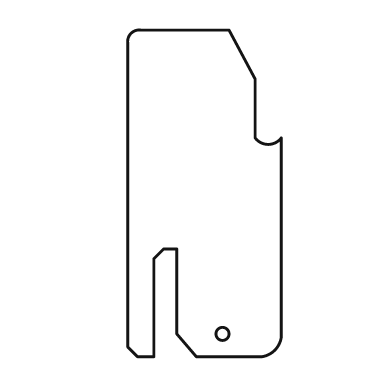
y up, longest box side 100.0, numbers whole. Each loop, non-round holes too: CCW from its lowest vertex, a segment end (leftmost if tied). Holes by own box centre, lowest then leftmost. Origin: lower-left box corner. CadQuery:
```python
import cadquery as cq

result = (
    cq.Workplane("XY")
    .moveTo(3.0, 0.0)
    .lineTo(8.0, 0.0)
    .lineTo(8.0, 30.0)
    .lineTo(11.0, 33.0)
    .lineTo(15.0, 33.0)
    .lineTo(15.0, 7.0)
    .lineTo(21.0, 0.0)
    .lineTo(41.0, 0.0)
    .threePointArc((45.0, 2.0), (47.0, 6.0))
    .lineTo(47.0, 67.0)
    .threePointArc((43.0, 65.0), (39.0, 67.0))
    .lineTo(39.0, 85.0)
    .lineTo(31.0, 100.0)
    .lineTo(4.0, 100.0)
    .threePointArc((1.0, 99.0), (0.0, 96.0))
    .lineTo(0.0, 3.0)
    .close()
    .moveTo(29.0, 7.0)
    .circle(2.0)
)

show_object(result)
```